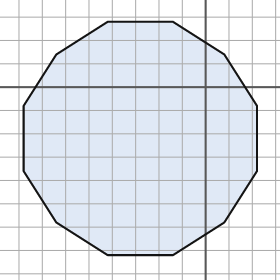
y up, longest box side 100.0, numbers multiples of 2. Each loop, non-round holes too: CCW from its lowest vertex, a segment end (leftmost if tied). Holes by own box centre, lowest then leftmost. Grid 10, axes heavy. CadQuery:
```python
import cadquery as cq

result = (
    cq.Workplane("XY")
    .moveTo(-42.0, -72.0)
    .lineTo(-14.0, -72.0)
    .lineTo(8.0, -58.0)
    .lineTo(22.0, -36.0)
    .lineTo(22.0, -8.0)
    .lineTo(8.0, 14.0)
    .lineTo(-14.0, 28.0)
    .lineTo(-42.0, 28.0)
    .lineTo(-64.0, 14.0)
    .lineTo(-78.0, -8.0)
    .lineTo(-78.0, -36.0)
    .lineTo(-64.0, -58.0)
    .close()
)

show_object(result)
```